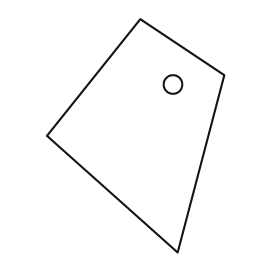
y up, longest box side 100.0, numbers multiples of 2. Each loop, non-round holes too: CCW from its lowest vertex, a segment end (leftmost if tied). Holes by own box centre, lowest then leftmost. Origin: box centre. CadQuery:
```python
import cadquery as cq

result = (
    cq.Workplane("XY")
    .moveTo(18.0, -50.0)
    .lineTo(38.0, 26.0)
    .lineTo(2.0, 50.0)
    .lineTo(-38.0, 0.0)
    .close()
    .moveTo(16.0, 22.0)
    .circle(4.0)
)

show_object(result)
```